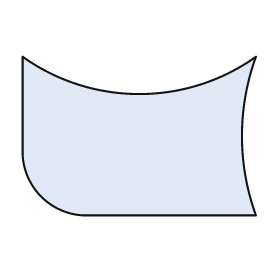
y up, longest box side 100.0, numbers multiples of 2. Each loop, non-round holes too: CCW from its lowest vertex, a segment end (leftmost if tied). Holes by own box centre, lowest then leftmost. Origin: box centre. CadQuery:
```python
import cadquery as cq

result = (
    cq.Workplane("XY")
    .moveTo(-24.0, -34.0)
    .lineTo(50.0, -34.0)
    .threePointArc((44.0, 0.0), (50.0, 34.0))
    .threePointArc((0.0, 18.0), (-50.0, 34.0))
    .lineTo(-50.0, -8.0)
    .threePointArc((-42.0, -26.0), (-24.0, -34.0))
    .close()
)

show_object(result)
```